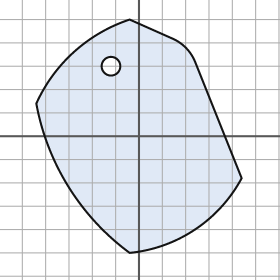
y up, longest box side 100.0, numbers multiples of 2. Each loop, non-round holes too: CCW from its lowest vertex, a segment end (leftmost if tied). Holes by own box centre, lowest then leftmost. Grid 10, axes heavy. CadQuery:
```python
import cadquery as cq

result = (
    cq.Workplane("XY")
    .moveTo(-4.0, -50.0)
    .threePointArc((24.0, -40.0), (44.0, -18.0))
    .lineTo(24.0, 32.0)
    .threePointArc((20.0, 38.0), (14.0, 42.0))
    .lineTo(-4.0, 50.0)
    .threePointArc((-28.0, 36.0), (-44.0, 14.0))
    .threePointArc((-30.0, -22.0), (-4.0, -50.0))
    .close()
    .moveTo(-12.0, 30.0)
    .circle(4.0)
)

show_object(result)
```